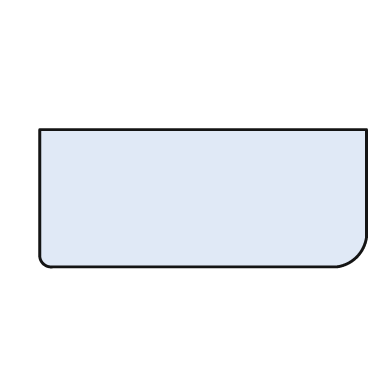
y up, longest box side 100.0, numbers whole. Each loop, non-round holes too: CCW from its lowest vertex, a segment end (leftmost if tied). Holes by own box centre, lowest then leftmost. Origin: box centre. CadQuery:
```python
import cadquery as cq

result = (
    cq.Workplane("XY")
    .moveTo(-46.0, -21.0)
    .lineTo(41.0, -21.0)
    .threePointArc((47.0, -18.0), (50.0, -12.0))
    .lineTo(50.0, 21.0)
    .lineTo(-50.0, 21.0)
    .lineTo(-50.0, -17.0)
    .threePointArc((-49.0, -20.0), (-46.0, -21.0))
    .close()
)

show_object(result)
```